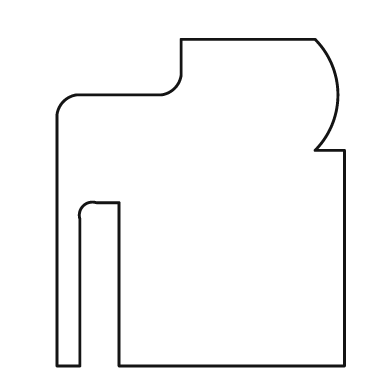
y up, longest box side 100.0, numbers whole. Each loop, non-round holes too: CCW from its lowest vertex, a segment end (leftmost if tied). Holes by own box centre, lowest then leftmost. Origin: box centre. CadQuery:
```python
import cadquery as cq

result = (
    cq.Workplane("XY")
    .moveTo(-44.0, -50.0)
    .lineTo(-37.0, -50.0)
    .lineTo(-37.0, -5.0)
    .threePointArc((-36.0, -1.0), (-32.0, 0.0))
    .lineTo(-25.0, 0.0)
    .lineTo(-25.0, -50.0)
    .lineTo(44.0, -50.0)
    .lineTo(44.0, 16.0)
    .lineTo(35.0, 16.0)
    .threePointArc((42.0, 33.0), (35.0, 50.0))
    .lineTo(-6.0, 50.0)
    .lineTo(-6.0, 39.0)
    .threePointArc((-8.0, 35.0), (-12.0, 33.0))
    .lineTo(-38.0, 33.0)
    .threePointArc((-42.0, 31.0), (-44.0, 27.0))
    .close()
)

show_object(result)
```